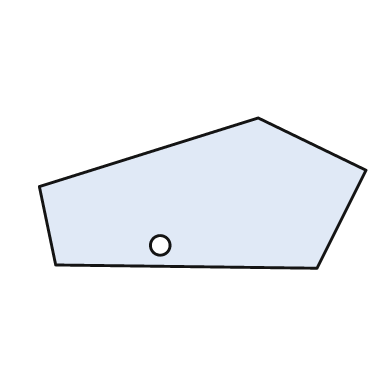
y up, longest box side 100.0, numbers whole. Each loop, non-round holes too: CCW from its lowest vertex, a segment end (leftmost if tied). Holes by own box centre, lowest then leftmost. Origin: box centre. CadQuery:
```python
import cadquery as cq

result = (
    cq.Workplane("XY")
    .moveTo(35.0, -23.0)
    .lineTo(50.0, 7.0)
    .lineTo(17.0, 23.0)
    .lineTo(-50.0, 2.0)
    .lineTo(-45.0, -22.0)
    .close()
    .moveTo(-13.0, -16.0)
    .circle(3.0)
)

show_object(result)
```